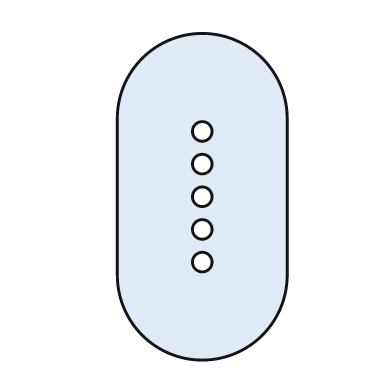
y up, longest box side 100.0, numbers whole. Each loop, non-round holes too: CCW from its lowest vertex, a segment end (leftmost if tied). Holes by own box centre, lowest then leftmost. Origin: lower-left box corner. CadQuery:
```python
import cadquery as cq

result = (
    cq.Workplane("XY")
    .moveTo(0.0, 26.0)
    .threePointArc((26.0, 0.0), (52.0, 26.0))
    .lineTo(52.0, 74.0)
    .threePointArc((26.0, 100.0), (0.0, 74.0))
    .close()
    .moveTo(26.0, 30.0)
    .circle(3.0)
    .moveTo(26.0, 40.0)
    .circle(3.0)
    .moveTo(26.0, 50.0)
    .circle(3.0)
    .moveTo(26.0, 60.0)
    .circle(3.0)
    .moveTo(26.0, 70.0)
    .circle(3.0)
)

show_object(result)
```